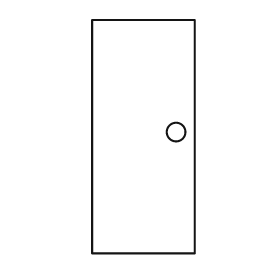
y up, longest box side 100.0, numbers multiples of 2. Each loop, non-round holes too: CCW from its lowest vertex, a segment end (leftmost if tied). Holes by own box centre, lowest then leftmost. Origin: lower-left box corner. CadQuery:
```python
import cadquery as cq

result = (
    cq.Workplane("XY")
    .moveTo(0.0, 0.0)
    .lineTo(44.0, 0.0)
    .lineTo(44.0, 100.0)
    .lineTo(0.0, 100.0)
    .close()
    .moveTo(36.0, 52.0)
    .circle(4.0)
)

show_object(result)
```